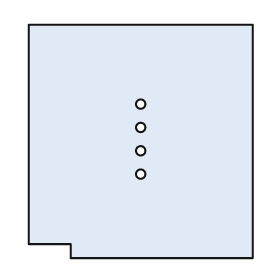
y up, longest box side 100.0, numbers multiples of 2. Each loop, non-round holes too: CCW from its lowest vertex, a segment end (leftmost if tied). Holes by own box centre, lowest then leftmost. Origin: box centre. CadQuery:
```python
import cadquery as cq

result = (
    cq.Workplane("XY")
    .moveTo(-30.0, -50.0)
    .lineTo(48.0, -50.0)
    .lineTo(48.0, 50.0)
    .lineTo(-48.0, 50.0)
    .lineTo(-48.0, -44.0)
    .lineTo(-30.0, -44.0)
    .close()
    .moveTo(0.0, -14.0)
    .circle(2.0)
    .moveTo(0.0, -4.0)
    .circle(2.0)
    .moveTo(0.0, 6.0)
    .circle(2.0)
    .moveTo(0.0, 16.0)
    .circle(2.0)
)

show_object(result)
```